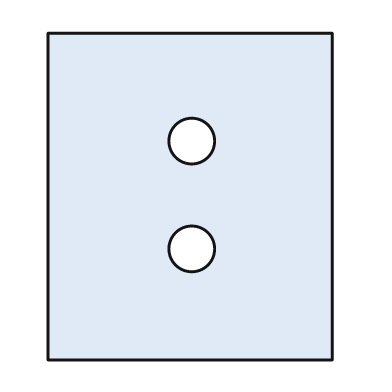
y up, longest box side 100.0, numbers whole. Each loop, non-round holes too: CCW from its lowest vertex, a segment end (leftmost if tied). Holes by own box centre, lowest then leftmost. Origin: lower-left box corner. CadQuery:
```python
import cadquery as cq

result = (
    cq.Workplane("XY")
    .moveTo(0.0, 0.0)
    .lineTo(87.0, 0.0)
    .lineTo(87.0, 100.0)
    .lineTo(0.0, 100.0)
    .close()
    .moveTo(44.0, 34.0)
    .circle(7.0)
    .moveTo(44.0, 67.0)
    .circle(7.0)
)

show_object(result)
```